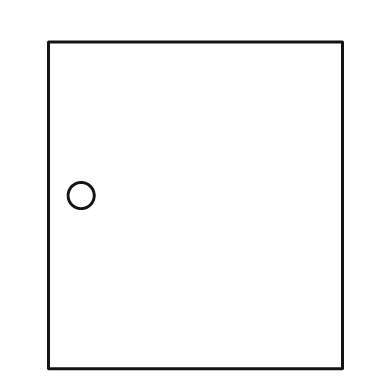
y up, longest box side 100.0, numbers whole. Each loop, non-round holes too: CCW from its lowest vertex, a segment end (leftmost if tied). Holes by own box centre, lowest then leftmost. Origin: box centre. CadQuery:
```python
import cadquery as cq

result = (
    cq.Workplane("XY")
    .moveTo(-45.0, -50.0)
    .lineTo(45.0, -50.0)
    .lineTo(45.0, 50.0)
    .lineTo(-45.0, 50.0)
    .close()
    .moveTo(-35.0, 3.0)
    .circle(4.0)
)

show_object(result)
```